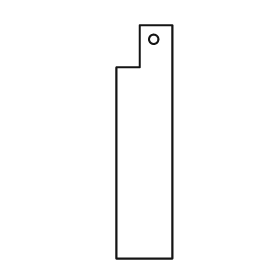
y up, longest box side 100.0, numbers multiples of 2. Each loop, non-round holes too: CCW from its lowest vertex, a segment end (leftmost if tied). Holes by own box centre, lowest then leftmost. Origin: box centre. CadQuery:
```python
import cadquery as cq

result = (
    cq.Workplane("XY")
    .moveTo(-12.0, -50.0)
    .lineTo(12.0, -50.0)
    .lineTo(12.0, 50.0)
    .lineTo(-2.0, 50.0)
    .lineTo(-2.0, 32.0)
    .lineTo(-12.0, 32.0)
    .close()
    .moveTo(4.0, 44.0)
    .circle(2.0)
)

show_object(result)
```